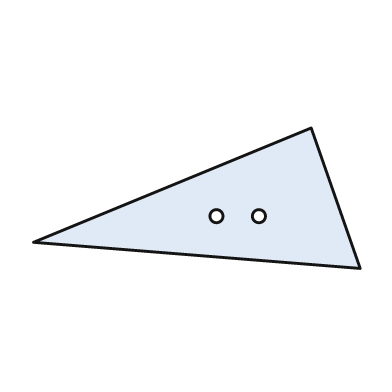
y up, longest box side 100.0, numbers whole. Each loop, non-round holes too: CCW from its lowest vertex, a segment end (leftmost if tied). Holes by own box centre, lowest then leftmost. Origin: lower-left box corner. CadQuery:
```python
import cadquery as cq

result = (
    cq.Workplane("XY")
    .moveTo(100.0, 0.0)
    .lineTo(85.0, 43.0)
    .lineTo(0.0, 8.0)
    .close()
    .moveTo(56.0, 16.0)
    .circle(2.0)
    .moveTo(69.0, 16.0)
    .circle(2.0)
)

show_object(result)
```